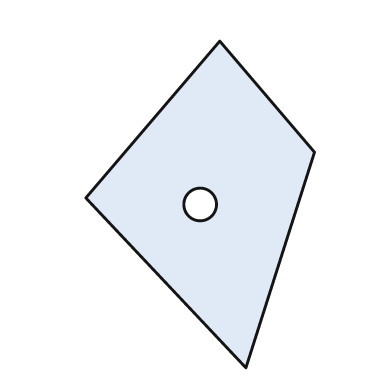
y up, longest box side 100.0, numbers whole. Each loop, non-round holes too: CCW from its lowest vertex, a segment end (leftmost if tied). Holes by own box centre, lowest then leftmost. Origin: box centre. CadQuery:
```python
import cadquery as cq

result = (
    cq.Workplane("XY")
    .moveTo(14.0, -50.0)
    .lineTo(35.0, 16.0)
    .lineTo(6.0, 50.0)
    .lineTo(-35.0, 2.0)
    .close()
    .moveTo(0.0, 0.0)
    .circle(5.0)
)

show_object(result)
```